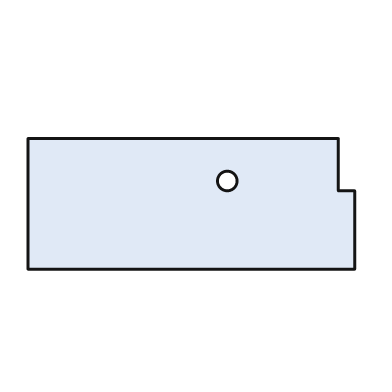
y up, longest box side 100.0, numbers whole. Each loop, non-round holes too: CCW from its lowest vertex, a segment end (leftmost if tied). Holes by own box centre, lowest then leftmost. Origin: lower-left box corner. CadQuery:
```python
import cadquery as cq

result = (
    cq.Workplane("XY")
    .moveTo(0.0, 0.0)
    .lineTo(100.0, 0.0)
    .lineTo(100.0, 24.0)
    .lineTo(95.0, 24.0)
    .lineTo(95.0, 40.0)
    .lineTo(0.0, 40.0)
    .close()
    .moveTo(61.0, 27.0)
    .circle(3.0)
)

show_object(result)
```